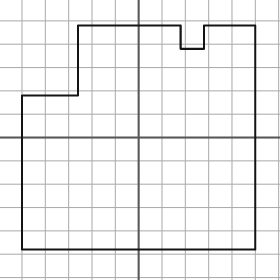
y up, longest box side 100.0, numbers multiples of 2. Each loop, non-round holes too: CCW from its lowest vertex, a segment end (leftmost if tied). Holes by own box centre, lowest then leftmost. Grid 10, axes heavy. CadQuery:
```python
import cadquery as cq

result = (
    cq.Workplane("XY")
    .moveTo(-50.0, -48.0)
    .lineTo(50.0, -48.0)
    .lineTo(50.0, 48.0)
    .lineTo(28.0, 48.0)
    .lineTo(28.0, 38.0)
    .lineTo(18.0, 38.0)
    .lineTo(18.0, 48.0)
    .lineTo(-26.0, 48.0)
    .lineTo(-26.0, 18.0)
    .lineTo(-50.0, 18.0)
    .close()
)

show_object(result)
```